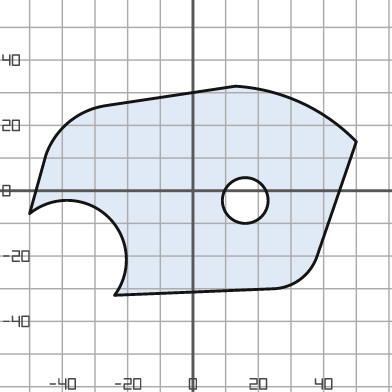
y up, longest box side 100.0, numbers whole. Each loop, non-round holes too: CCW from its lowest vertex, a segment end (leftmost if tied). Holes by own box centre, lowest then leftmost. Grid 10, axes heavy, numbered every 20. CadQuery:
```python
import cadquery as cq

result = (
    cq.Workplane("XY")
    .moveTo(-24.0, -32.0)
    .lineTo(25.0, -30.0)
    .threePointArc((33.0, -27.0), (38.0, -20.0))
    .lineTo(50.0, 15.0)
    .threePointArc((33.0, 27.0), (13.0, 32.0))
    .lineTo(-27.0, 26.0)
    .threePointArc((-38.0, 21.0), (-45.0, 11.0))
    .lineTo(-50.0, -7.0)
    .threePointArc((-26.0, -8.0), (-24.0, -32.0))
    .close()
    .moveTo(16.0, -3.0)
    .circle(7.0)
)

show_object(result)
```